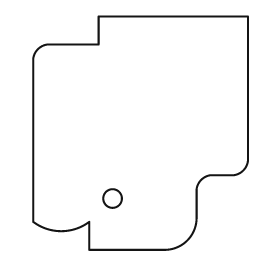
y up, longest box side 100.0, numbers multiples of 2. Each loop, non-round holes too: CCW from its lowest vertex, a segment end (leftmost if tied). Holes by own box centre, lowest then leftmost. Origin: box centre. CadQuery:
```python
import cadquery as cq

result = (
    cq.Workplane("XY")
    .moveTo(-22.0, -50.0)
    .lineTo(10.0, -50.0)
    .threePointArc((20.0, -46.0), (24.0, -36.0))
    .lineTo(24.0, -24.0)
    .threePointArc((26.0, -20.0), (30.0, -18.0))
    .lineTo(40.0, -18.0)
    .threePointArc((44.0, -16.0), (46.0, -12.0))
    .lineTo(46.0, 50.0)
    .lineTo(-18.0, 50.0)
    .lineTo(-18.0, 38.0)
    .lineTo(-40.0, 38.0)
    .threePointArc((-44.0, 36.0), (-46.0, 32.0))
    .lineTo(-46.0, -38.0)
    .threePointArc((-34.0, -42.0), (-22.0, -38.0))
    .close()
    .moveTo(-12.0, -28.0)
    .circle(4.0)
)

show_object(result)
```